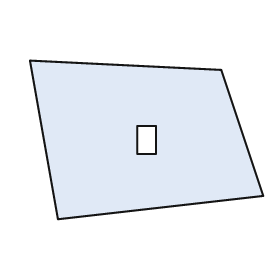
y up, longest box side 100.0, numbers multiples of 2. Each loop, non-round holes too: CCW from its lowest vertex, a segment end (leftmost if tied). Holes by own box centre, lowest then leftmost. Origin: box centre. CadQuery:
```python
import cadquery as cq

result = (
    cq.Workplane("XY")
    .moveTo(-38.0, -34.0)
    .lineTo(50.0, -24.0)
    .lineTo(32.0, 30.0)
    .lineTo(-50.0, 34.0)
    .close()
    .moveTo(-4.0, -6.0)
    .lineTo(4.0, -6.0)
    .lineTo(4.0, 6.0)
    .lineTo(-4.0, 6.0)
    .close()
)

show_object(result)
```